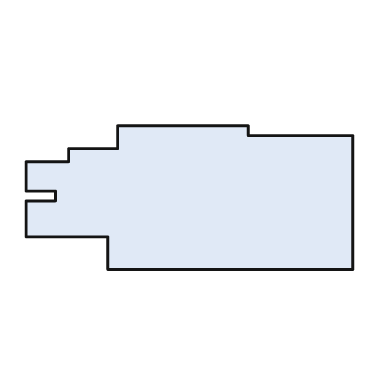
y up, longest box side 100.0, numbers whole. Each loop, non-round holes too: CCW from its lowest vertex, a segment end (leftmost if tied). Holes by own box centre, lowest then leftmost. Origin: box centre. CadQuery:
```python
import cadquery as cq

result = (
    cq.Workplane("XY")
    .moveTo(-25.0, -22.0)
    .lineTo(50.0, -22.0)
    .lineTo(50.0, 19.0)
    .lineTo(18.0, 19.0)
    .lineTo(18.0, 22.0)
    .lineTo(-22.0, 22.0)
    .lineTo(-22.0, 15.0)
    .lineTo(-37.0, 15.0)
    .lineTo(-37.0, 11.0)
    .lineTo(-50.0, 11.0)
    .lineTo(-50.0, 2.0)
    .lineTo(-41.0, 2.0)
    .lineTo(-41.0, -1.0)
    .lineTo(-50.0, -1.0)
    .lineTo(-50.0, -12.0)
    .lineTo(-25.0, -12.0)
    .close()
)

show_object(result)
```